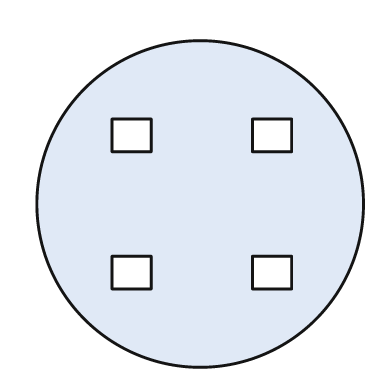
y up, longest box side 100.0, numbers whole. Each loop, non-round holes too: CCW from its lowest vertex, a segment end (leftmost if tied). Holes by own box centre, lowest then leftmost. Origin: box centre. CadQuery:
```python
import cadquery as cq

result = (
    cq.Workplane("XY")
    .moveTo(0.0, 0.0)
    .circle(50.0)
    .moveTo(-27.0, -26.0)
    .lineTo(-15.0, -26.0)
    .lineTo(-15.0, -16.0)
    .lineTo(-27.0, -16.0)
    .close()
    .moveTo(16.0, -26.0)
    .lineTo(28.0, -26.0)
    .lineTo(28.0, -16.0)
    .lineTo(16.0, -16.0)
    .close()
    .moveTo(-27.0, 16.0)
    .lineTo(-15.0, 16.0)
    .lineTo(-15.0, 26.0)
    .lineTo(-27.0, 26.0)
    .close()
    .moveTo(16.0, 16.0)
    .lineTo(28.0, 16.0)
    .lineTo(28.0, 26.0)
    .lineTo(16.0, 26.0)
    .close()
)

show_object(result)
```